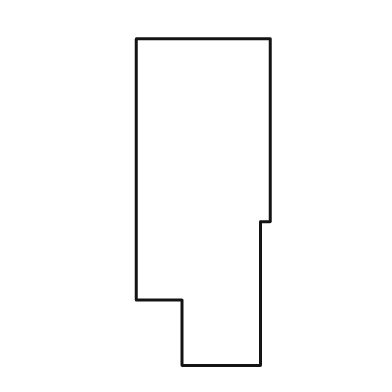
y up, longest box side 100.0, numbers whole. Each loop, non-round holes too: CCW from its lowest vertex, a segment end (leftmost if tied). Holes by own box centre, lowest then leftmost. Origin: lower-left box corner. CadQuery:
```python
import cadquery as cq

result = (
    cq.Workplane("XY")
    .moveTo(14.0, 0.0)
    .lineTo(38.0, 0.0)
    .lineTo(38.0, 44.0)
    .lineTo(41.0, 44.0)
    .lineTo(41.0, 100.0)
    .lineTo(0.0, 100.0)
    .lineTo(0.0, 20.0)
    .lineTo(14.0, 20.0)
    .close()
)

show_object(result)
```